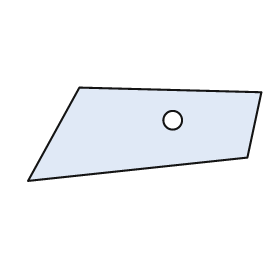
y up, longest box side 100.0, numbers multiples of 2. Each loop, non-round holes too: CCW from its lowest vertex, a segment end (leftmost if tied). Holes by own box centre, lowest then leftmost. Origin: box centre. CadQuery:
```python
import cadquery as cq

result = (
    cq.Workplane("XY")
    .moveTo(-50.0, -20.0)
    .lineTo(44.0, -10.0)
    .lineTo(50.0, 18.0)
    .lineTo(-28.0, 20.0)
    .close()
    .moveTo(12.0, 6.0)
    .circle(4.0)
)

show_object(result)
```